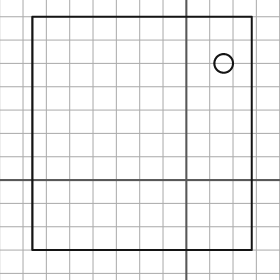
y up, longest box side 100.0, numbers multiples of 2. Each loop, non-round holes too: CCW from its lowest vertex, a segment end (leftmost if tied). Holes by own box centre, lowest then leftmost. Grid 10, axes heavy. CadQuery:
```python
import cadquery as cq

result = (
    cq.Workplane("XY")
    .moveTo(-66.0, -30.0)
    .lineTo(28.0, -30.0)
    .lineTo(28.0, 70.0)
    .lineTo(-66.0, 70.0)
    .close()
    .moveTo(16.0, 50.0)
    .circle(4.0)
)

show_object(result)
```